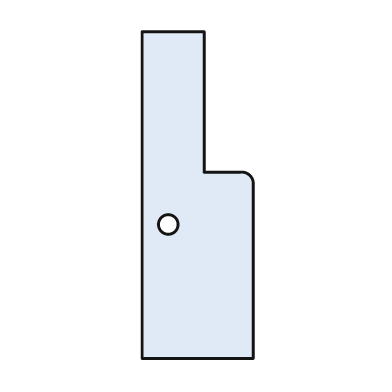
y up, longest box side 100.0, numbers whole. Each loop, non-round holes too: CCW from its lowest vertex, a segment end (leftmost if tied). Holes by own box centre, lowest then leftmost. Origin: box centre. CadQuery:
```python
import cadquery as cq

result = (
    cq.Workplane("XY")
    .moveTo(-17.0, -50.0)
    .lineTo(17.0, -50.0)
    .lineTo(17.0, 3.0)
    .threePointArc((16.0, 6.0), (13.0, 7.0))
    .lineTo(2.0, 7.0)
    .lineTo(2.0, 50.0)
    .lineTo(-17.0, 50.0)
    .close()
    .moveTo(-9.0, -9.0)
    .circle(3.0)
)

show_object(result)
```